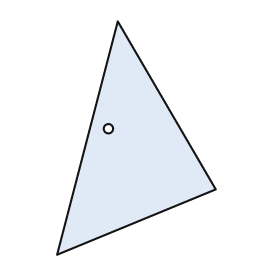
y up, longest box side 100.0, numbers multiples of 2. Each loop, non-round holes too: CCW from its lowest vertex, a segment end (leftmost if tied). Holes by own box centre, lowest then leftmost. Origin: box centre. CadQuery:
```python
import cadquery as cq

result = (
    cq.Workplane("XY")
    .moveTo(-34.0, -50.0)
    .lineTo(34.0, -22.0)
    .lineTo(-8.0, 50.0)
    .close()
    .moveTo(-12.0, 4.0)
    .circle(2.0)
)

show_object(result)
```